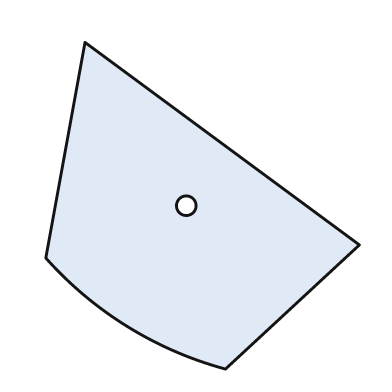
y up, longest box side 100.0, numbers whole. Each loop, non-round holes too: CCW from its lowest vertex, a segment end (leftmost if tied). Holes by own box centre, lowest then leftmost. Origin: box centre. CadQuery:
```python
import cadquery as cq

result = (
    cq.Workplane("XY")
    .moveTo(7.0, -50.0)
    .lineTo(48.0, -12.0)
    .lineTo(-36.0, 50.0)
    .lineTo(-48.0, -16.0)
    .threePointArc((-23.0, -37.0), (7.0, -50.0))
    .close()
    .moveTo(-5.0, 0.0)
    .circle(3.0)
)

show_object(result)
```